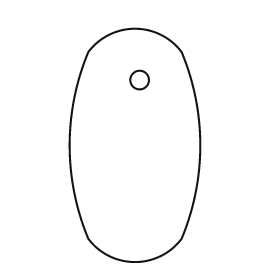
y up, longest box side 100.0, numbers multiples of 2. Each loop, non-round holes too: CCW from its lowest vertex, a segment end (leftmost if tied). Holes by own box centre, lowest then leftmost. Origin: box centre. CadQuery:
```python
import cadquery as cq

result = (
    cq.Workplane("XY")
    .moveTo(-20.0, -40.0)
    .threePointArc((0.0, -50.0), (20.0, -40.0))
    .threePointArc((28.0, 0.0), (20.0, 40.0))
    .threePointArc((0.0, 50.0), (-20.0, 40.0))
    .threePointArc((-28.0, 0.0), (-20.0, -40.0))
    .close()
    .moveTo(2.0, 28.0)
    .circle(4.0)
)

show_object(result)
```